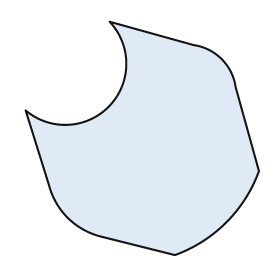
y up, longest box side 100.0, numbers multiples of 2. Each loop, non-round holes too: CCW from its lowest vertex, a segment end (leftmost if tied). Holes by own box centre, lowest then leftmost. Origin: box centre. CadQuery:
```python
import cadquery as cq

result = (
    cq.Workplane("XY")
    .moveTo(14.0, -50.0)
    .threePointArc((36.0, -36.0), (50.0, -14.0))
    .lineTo(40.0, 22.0)
    .threePointArc((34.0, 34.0), (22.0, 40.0))
    .lineTo(-14.0, 50.0)
    .threePointArc((-14.0, 14.0), (-50.0, 12.0))
    .lineTo(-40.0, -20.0)
    .threePointArc((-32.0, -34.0), (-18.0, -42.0))
    .close()
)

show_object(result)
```